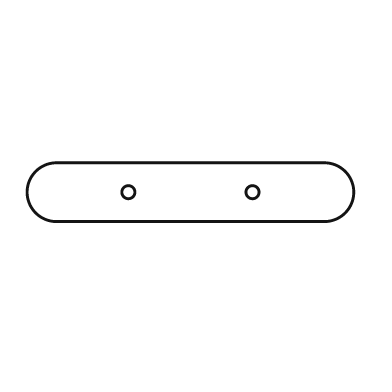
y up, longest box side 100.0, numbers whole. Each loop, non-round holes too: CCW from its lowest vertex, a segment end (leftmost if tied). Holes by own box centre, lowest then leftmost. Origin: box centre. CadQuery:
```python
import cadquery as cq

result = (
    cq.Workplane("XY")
    .moveTo(-41.0, -9.0)
    .lineTo(41.0, -9.0)
    .threePointArc((50.0, 0.0), (41.0, 9.0))
    .lineTo(-41.0, 9.0)
    .threePointArc((-50.0, 0.0), (-41.0, -9.0))
    .close()
    .moveTo(-19.0, 0.0)
    .circle(2.0)
    .moveTo(19.0, 0.0)
    .circle(2.0)
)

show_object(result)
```